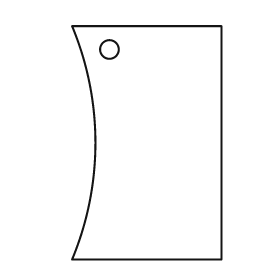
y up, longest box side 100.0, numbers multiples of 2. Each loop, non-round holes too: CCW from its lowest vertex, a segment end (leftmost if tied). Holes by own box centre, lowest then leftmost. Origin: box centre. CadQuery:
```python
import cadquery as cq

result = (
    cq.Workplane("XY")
    .moveTo(-32.0, -50.0)
    .lineTo(32.0, -50.0)
    .lineTo(32.0, 50.0)
    .lineTo(-32.0, 50.0)
    .threePointArc((-22.0, 0.0), (-32.0, -50.0))
    .close()
    .moveTo(-16.0, 40.0)
    .circle(4.0)
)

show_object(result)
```